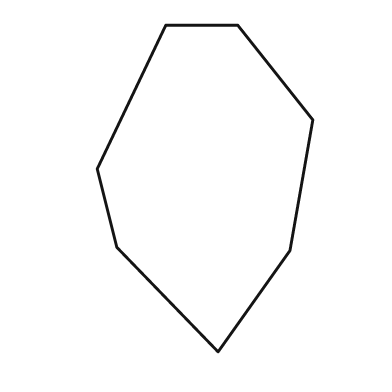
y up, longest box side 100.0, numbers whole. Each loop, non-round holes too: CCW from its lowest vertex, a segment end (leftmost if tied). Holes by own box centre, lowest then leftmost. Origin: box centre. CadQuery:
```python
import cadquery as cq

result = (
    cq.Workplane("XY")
    .moveTo(4.0, -50.0)
    .lineTo(26.0, -19.0)
    .lineTo(33.0, 21.0)
    .lineTo(10.0, 50.0)
    .lineTo(-12.0, 50.0)
    .lineTo(-33.0, 6.0)
    .lineTo(-27.0, -18.0)
    .close()
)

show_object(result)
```